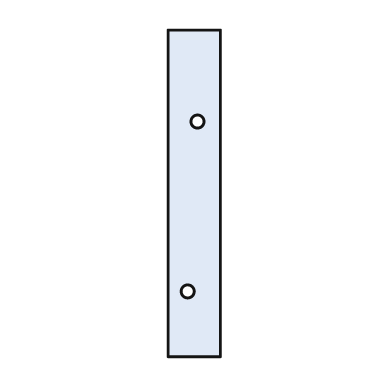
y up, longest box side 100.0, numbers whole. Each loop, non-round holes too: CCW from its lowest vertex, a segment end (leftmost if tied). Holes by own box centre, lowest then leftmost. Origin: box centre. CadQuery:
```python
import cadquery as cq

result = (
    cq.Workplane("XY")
    .moveTo(-8.0, -50.0)
    .lineTo(8.0, -50.0)
    .lineTo(8.0, 50.0)
    .lineTo(-8.0, 50.0)
    .close()
    .moveTo(-2.0, -30.0)
    .circle(2.0)
    .moveTo(1.0, 22.0)
    .circle(2.0)
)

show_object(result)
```